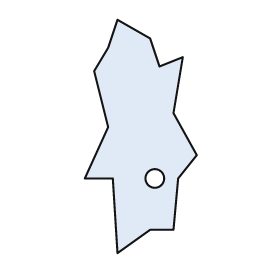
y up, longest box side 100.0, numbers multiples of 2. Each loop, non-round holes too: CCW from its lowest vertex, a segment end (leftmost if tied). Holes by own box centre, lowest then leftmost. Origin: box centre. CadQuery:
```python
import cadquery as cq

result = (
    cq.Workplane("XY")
    .moveTo(-10.0, -50.0)
    .lineTo(4.0, -40.0)
    .lineTo(14.0, -40.0)
    .lineTo(16.0, -18.0)
    .lineTo(24.0, -8.0)
    .lineTo(14.0, 10.0)
    .lineTo(18.0, 34.0)
    .lineTo(8.0, 30.0)
    .lineTo(4.0, 42.0)
    .lineTo(-10.0, 50.0)
    .lineTo(-14.0, 38.0)
    .lineTo(-20.0, 28.0)
    .lineTo(-14.0, 4.0)
    .lineTo(-24.0, -18.0)
    .lineTo(-12.0, -18.0)
    .close()
    .moveTo(6.0, -18.0)
    .circle(4.0)
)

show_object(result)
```